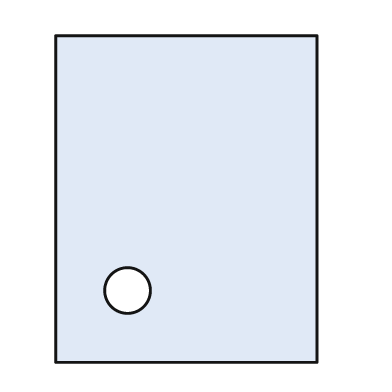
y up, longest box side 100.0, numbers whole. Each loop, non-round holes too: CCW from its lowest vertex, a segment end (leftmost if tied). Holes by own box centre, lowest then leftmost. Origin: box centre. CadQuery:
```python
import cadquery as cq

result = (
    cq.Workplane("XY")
    .moveTo(-40.0, -50.0)
    .lineTo(40.0, -50.0)
    .lineTo(40.0, 50.0)
    .lineTo(-40.0, 50.0)
    .close()
    .moveTo(-18.0, -28.0)
    .circle(7.0)
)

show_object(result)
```